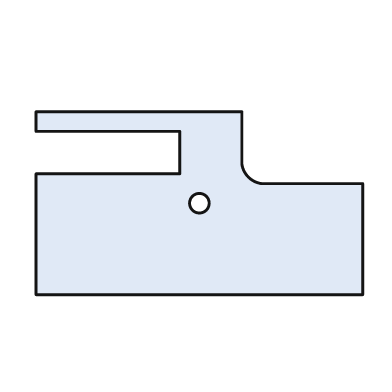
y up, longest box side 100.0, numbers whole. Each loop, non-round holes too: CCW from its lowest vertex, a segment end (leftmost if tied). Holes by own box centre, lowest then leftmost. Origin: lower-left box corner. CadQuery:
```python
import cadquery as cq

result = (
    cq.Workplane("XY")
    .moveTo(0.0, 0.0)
    .lineTo(100.0, 0.0)
    .lineTo(100.0, 34.0)
    .lineTo(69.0, 34.0)
    .threePointArc((65.0, 36.0), (63.0, 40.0))
    .lineTo(63.0, 56.0)
    .lineTo(0.0, 56.0)
    .lineTo(0.0, 50.0)
    .lineTo(44.0, 50.0)
    .lineTo(44.0, 37.0)
    .lineTo(0.0, 37.0)
    .close()
    .moveTo(50.0, 28.0)
    .circle(3.0)
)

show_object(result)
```